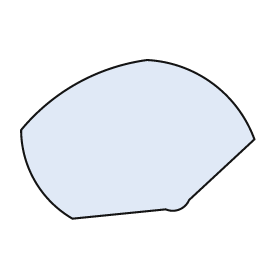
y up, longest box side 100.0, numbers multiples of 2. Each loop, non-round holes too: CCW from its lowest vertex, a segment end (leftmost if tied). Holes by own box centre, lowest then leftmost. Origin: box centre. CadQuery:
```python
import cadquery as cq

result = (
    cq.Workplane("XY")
    .moveTo(-28.0, -34.0)
    .lineTo(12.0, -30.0)
    .threePointArc((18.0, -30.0), (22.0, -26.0))
    .lineTo(50.0, 0.0)
    .threePointArc((32.0, 24.0), (4.0, 34.0))
    .threePointArc((-26.0, 24.0), (-50.0, 4.0))
    .threePointArc((-44.0, -18.0), (-28.0, -34.0))
    .close()
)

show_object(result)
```